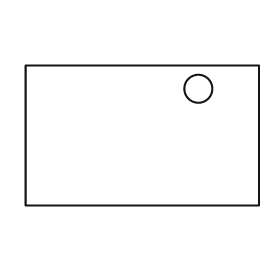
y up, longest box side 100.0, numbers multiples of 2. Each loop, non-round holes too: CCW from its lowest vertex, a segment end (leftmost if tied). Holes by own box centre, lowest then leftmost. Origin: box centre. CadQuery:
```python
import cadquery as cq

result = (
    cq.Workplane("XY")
    .moveTo(-50.0, -30.0)
    .lineTo(50.0, -30.0)
    .lineTo(50.0, 30.0)
    .lineTo(-50.0, 30.0)
    .close()
    .moveTo(24.0, 20.0)
    .circle(6.0)
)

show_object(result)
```